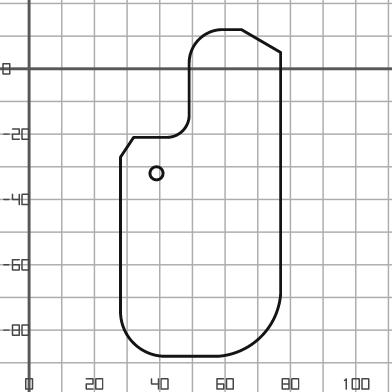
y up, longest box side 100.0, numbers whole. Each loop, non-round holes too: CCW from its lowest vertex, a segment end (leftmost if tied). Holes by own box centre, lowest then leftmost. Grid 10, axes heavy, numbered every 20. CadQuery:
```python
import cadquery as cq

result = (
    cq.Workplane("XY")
    .moveTo(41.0, -88.0)
    .lineTo(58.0, -88.0)
    .threePointArc((71.0, -82.0), (77.0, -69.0))
    .lineTo(77.0, 5.0)
    .lineTo(65.0, 12.0)
    .lineTo(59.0, 12.0)
    .threePointArc((52.0, 9.0), (49.0, 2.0))
    .lineTo(49.0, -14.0)
    .threePointArc((47.0, -19.0), (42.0, -21.0))
    .lineTo(32.0, -21.0)
    .lineTo(28.0, -27.0)
    .lineTo(28.0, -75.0)
    .threePointArc((32.0, -84.0), (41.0, -88.0))
    .close()
    .moveTo(39.0, -32.0)
    .circle(2.0)
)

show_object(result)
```